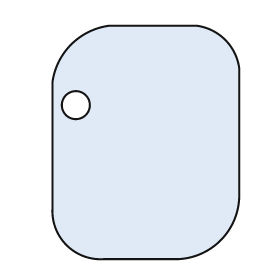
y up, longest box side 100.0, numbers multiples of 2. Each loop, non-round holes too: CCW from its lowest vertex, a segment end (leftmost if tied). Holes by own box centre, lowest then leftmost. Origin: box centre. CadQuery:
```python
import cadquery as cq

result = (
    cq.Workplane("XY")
    .moveTo(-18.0, -50.0)
    .lineTo(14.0, -50.0)
    .threePointArc((32.0, -42.0), (40.0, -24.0))
    .lineTo(40.0, 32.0)
    .threePointArc((34.0, 44.0), (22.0, 50.0))
    .lineTo(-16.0, 50.0)
    .threePointArc((-32.0, 42.0), (-40.0, 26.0))
    .lineTo(-40.0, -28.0)
    .threePointArc((-34.0, -44.0), (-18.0, -50.0))
    .close()
    .moveTo(-30.0, 16.0)
    .circle(6.0)
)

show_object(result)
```